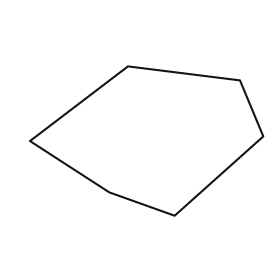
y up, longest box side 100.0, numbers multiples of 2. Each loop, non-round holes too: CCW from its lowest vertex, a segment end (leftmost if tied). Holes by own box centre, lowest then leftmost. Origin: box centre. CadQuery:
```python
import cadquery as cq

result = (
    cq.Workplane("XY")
    .moveTo(12.0, -32.0)
    .lineTo(50.0, 2.0)
    .lineTo(40.0, 26.0)
    .lineTo(-8.0, 32.0)
    .lineTo(-50.0, 0.0)
    .lineTo(-16.0, -22.0)
    .close()
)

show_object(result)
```